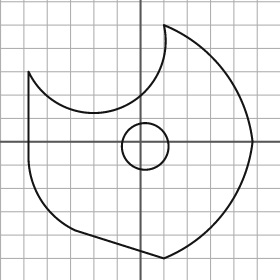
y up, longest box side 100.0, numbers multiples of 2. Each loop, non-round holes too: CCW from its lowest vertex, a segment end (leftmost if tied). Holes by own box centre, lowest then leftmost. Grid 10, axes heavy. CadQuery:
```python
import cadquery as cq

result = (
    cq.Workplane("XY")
    .moveTo(10.0, -50.0)
    .threePointArc((36.0, -30.0), (48.0, 0.0))
    .threePointArc((36.0, 30.0), (10.0, 50.0))
    .threePointArc((-10.0, 14.0), (-48.0, 30.0))
    .lineTo(-48.0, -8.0)
    .threePointArc((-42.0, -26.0), (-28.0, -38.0))
    .close()
    .moveTo(2.0, -2.0)
    .circle(10.0)
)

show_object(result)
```